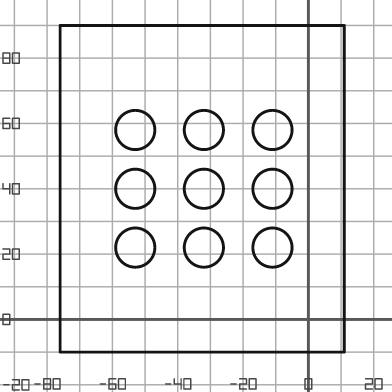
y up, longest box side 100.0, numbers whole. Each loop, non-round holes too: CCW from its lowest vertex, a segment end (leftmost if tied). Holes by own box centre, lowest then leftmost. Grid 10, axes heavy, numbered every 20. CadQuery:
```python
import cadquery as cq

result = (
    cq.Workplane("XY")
    .moveTo(-76.0, -10.0)
    .lineTo(11.0, -10.0)
    .lineTo(11.0, 90.0)
    .lineTo(-76.0, 90.0)
    .close()
    .moveTo(-53.0, 22.0)
    .circle(6.0)
    .moveTo(-32.0, 22.0)
    .circle(6.0)
    .moveTo(-11.0, 22.0)
    .circle(6.0)
    .moveTo(-53.0, 40.0)
    .circle(6.0)
    .moveTo(-32.0, 40.0)
    .circle(6.0)
    .moveTo(-11.0, 40.0)
    .circle(6.0)
    .moveTo(-53.0, 58.0)
    .circle(6.0)
    .moveTo(-32.0, 58.0)
    .circle(6.0)
    .moveTo(-11.0, 58.0)
    .circle(6.0)
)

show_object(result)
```